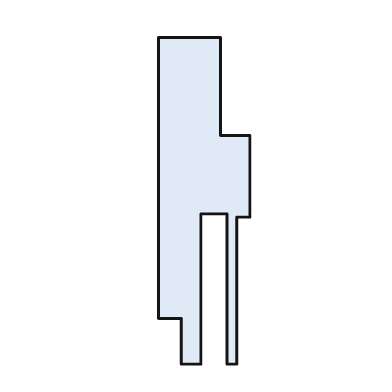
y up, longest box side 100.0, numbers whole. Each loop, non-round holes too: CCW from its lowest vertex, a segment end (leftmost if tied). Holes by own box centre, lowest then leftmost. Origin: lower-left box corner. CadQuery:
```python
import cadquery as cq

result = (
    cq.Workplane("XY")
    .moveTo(7.0, 0.0)
    .lineTo(13.0, 0.0)
    .lineTo(13.0, 46.0)
    .lineTo(21.0, 46.0)
    .lineTo(21.0, 0.0)
    .lineTo(24.0, 0.0)
    .lineTo(24.0, 45.0)
    .lineTo(28.0, 45.0)
    .lineTo(28.0, 70.0)
    .lineTo(19.0, 70.0)
    .lineTo(19.0, 100.0)
    .lineTo(0.0, 100.0)
    .lineTo(0.0, 14.0)
    .lineTo(7.0, 14.0)
    .close()
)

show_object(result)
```